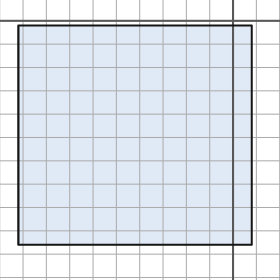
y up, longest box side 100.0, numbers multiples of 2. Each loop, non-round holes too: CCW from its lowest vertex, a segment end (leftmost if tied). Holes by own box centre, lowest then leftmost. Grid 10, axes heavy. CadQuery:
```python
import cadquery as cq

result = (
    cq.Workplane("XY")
    .moveTo(-92.0, -96.0)
    .lineTo(8.0, -96.0)
    .lineTo(8.0, -2.0)
    .lineTo(-92.0, -2.0)
    .close()
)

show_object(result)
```